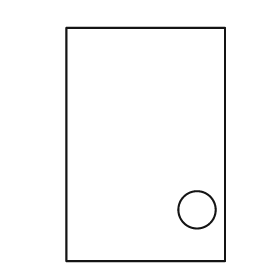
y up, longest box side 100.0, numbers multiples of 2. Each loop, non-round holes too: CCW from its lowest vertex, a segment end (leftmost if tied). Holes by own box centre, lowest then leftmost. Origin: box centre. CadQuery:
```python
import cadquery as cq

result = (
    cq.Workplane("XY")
    .moveTo(-34.0, -50.0)
    .lineTo(34.0, -50.0)
    .lineTo(34.0, 50.0)
    .lineTo(-34.0, 50.0)
    .close()
    .moveTo(22.0, -28.0)
    .circle(8.0)
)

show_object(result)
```